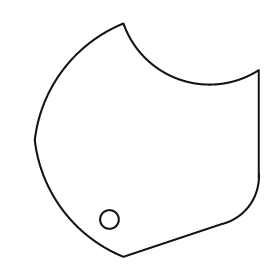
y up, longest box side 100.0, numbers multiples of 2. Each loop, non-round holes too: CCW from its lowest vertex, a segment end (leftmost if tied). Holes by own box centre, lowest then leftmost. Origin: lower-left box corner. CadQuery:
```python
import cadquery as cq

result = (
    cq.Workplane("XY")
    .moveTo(38.0, 0.0)
    .lineTo(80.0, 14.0)
    .threePointArc((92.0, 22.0), (96.0, 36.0))
    .lineTo(96.0, 80.0)
    .threePointArc((62.0, 76.0), (38.0, 100.0))
    .threePointArc((12.0, 80.0), (0.0, 50.0))
    .threePointArc((12.0, 20.0), (38.0, 0.0))
    .close()
    .moveTo(32.0, 16.0)
    .circle(4.0)
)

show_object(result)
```